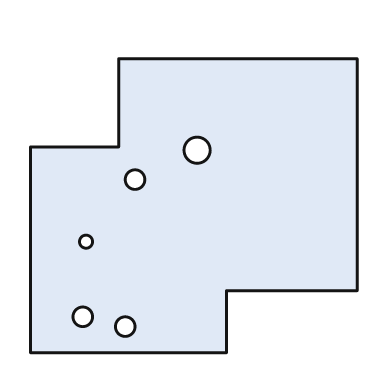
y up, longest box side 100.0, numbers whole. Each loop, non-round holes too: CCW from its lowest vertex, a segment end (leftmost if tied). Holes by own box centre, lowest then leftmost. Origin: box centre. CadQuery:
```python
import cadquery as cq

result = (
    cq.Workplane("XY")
    .moveTo(-50.0, -45.0)
    .lineTo(10.0, -45.0)
    .lineTo(10.0, -26.0)
    .lineTo(50.0, -26.0)
    .lineTo(50.0, 45.0)
    .lineTo(-23.0, 45.0)
    .lineTo(-23.0, 18.0)
    .lineTo(-50.0, 18.0)
    .close()
    .moveTo(-21.0, -37.0)
    .circle(3.0)
    .moveTo(-34.0, -34.0)
    .circle(3.0)
    .moveTo(-33.0, -11.0)
    .circle(2.0)
    .moveTo(-18.0, 8.0)
    .circle(3.0)
    .moveTo(1.0, 17.0)
    .circle(4.0)
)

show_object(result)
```